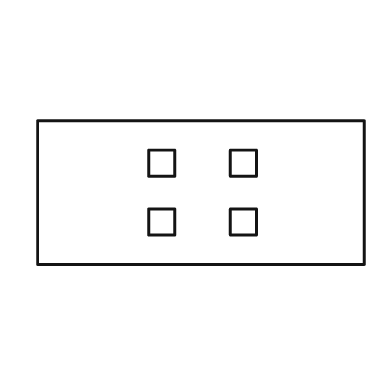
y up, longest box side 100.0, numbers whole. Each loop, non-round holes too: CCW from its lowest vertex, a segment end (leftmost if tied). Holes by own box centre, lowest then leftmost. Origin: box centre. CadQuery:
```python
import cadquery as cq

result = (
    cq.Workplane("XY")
    .moveTo(-50.0, -22.0)
    .lineTo(50.0, -22.0)
    .lineTo(50.0, 22.0)
    .lineTo(-50.0, 22.0)
    .close()
    .moveTo(-16.0, -13.0)
    .lineTo(-8.0, -13.0)
    .lineTo(-8.0, -5.0)
    .lineTo(-16.0, -5.0)
    .close()
    .moveTo(9.0, -13.0)
    .lineTo(17.0, -13.0)
    .lineTo(17.0, -5.0)
    .lineTo(9.0, -5.0)
    .close()
    .moveTo(-16.0, 5.0)
    .lineTo(-8.0, 5.0)
    .lineTo(-8.0, 13.0)
    .lineTo(-16.0, 13.0)
    .close()
    .moveTo(9.0, 5.0)
    .lineTo(17.0, 5.0)
    .lineTo(17.0, 13.0)
    .lineTo(9.0, 13.0)
    .close()
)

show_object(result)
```